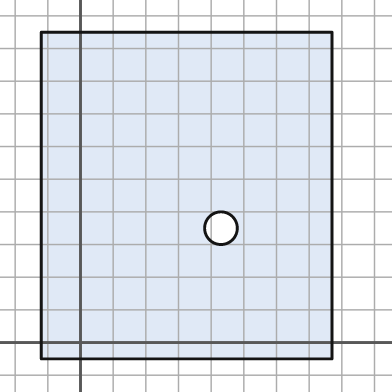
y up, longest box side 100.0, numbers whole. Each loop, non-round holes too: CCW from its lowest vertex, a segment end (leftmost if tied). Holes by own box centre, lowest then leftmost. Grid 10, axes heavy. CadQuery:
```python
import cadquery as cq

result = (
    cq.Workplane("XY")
    .moveTo(-12.0, -5.0)
    .lineTo(77.0, -5.0)
    .lineTo(77.0, 95.0)
    .lineTo(-12.0, 95.0)
    .close()
    .moveTo(43.0, 35.0)
    .circle(5.0)
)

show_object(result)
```